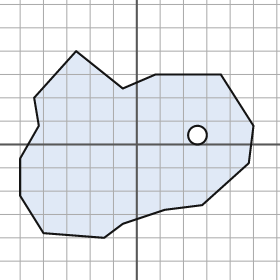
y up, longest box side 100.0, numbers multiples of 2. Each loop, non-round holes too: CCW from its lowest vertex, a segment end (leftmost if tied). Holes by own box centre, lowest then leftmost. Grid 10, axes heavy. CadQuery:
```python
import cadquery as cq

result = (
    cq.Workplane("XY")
    .moveTo(-14.0, -40.0)
    .lineTo(-6.0, -34.0)
    .lineTo(12.0, -28.0)
    .lineTo(28.0, -26.0)
    .lineTo(48.0, -8.0)
    .lineTo(50.0, 8.0)
    .lineTo(36.0, 30.0)
    .lineTo(8.0, 30.0)
    .lineTo(-6.0, 24.0)
    .lineTo(-26.0, 40.0)
    .lineTo(-44.0, 20.0)
    .lineTo(-42.0, 8.0)
    .lineTo(-50.0, -6.0)
    .lineTo(-50.0, -22.0)
    .lineTo(-40.0, -38.0)
    .close()
    .moveTo(26.0, 4.0)
    .circle(4.0)
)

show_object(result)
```